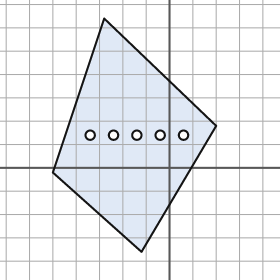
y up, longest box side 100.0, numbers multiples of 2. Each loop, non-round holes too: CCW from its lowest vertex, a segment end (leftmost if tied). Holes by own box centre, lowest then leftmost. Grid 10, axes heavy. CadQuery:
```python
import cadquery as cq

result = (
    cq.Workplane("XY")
    .moveTo(-12.0, -36.0)
    .lineTo(20.0, 18.0)
    .lineTo(-28.0, 64.0)
    .lineTo(-50.0, -2.0)
    .close()
    .moveTo(-34.0, 14.0)
    .circle(2.0)
    .moveTo(-24.0, 14.0)
    .circle(2.0)
    .moveTo(-14.0, 14.0)
    .circle(2.0)
    .moveTo(-4.0, 14.0)
    .circle(2.0)
    .moveTo(6.0, 14.0)
    .circle(2.0)
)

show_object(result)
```